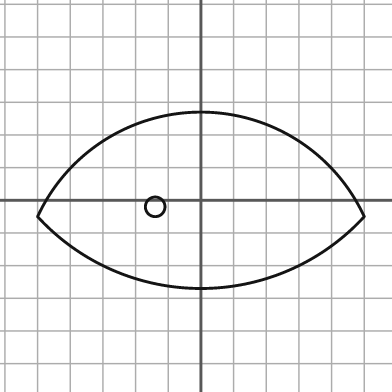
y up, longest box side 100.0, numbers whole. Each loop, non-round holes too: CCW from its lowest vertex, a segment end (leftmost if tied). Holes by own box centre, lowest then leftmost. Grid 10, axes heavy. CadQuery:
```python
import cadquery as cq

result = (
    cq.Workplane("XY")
    .moveTo(-50.0, -5.0)
    .threePointArc((0.0, -27.0), (50.0, -5.0))
    .threePointArc((0.0, 27.0), (-50.0, -5.0))
    .close()
    .moveTo(-14.0, -2.0)
    .circle(3.0)
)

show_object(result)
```